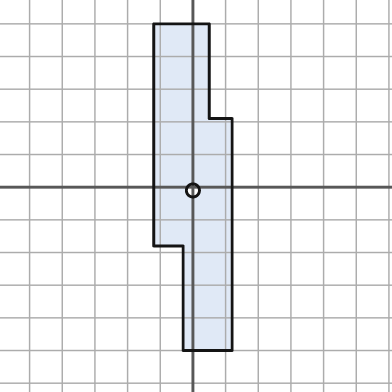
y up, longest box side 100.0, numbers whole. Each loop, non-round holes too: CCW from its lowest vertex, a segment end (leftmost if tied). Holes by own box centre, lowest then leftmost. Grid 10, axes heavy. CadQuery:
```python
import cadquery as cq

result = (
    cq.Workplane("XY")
    .moveTo(-3.0, -50.0)
    .lineTo(12.0, -50.0)
    .lineTo(12.0, 21.0)
    .lineTo(5.0, 21.0)
    .lineTo(5.0, 50.0)
    .lineTo(-12.0, 50.0)
    .lineTo(-12.0, -18.0)
    .lineTo(-3.0, -18.0)
    .close()
    .moveTo(0.0, -1.0)
    .circle(2.0)
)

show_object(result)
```